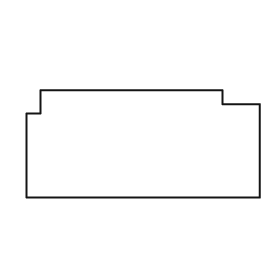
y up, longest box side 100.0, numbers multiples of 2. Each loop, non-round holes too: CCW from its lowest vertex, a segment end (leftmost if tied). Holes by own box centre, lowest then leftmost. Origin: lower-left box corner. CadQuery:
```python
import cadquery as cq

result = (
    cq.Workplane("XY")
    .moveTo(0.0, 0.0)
    .lineTo(100.0, 0.0)
    .lineTo(100.0, 40.0)
    .lineTo(84.0, 40.0)
    .lineTo(84.0, 46.0)
    .lineTo(6.0, 46.0)
    .lineTo(6.0, 36.0)
    .lineTo(0.0, 36.0)
    .close()
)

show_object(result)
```